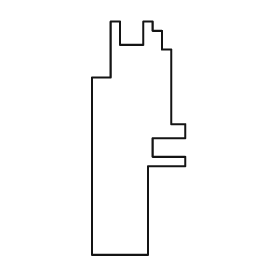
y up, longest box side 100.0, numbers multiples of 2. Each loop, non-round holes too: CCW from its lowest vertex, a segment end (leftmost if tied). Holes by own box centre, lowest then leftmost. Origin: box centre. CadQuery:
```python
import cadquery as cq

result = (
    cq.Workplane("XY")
    .moveTo(-20.0, -50.0)
    .lineTo(4.0, -50.0)
    .lineTo(4.0, -12.0)
    .lineTo(20.0, -12.0)
    .lineTo(20.0, -8.0)
    .lineTo(6.0, -8.0)
    .lineTo(6.0, 0.0)
    .lineTo(20.0, 0.0)
    .lineTo(20.0, 6.0)
    .lineTo(14.0, 6.0)
    .lineTo(14.0, 38.0)
    .lineTo(10.0, 38.0)
    .lineTo(10.0, 46.0)
    .lineTo(6.0, 46.0)
    .lineTo(6.0, 50.0)
    .lineTo(2.0, 50.0)
    .lineTo(2.0, 40.0)
    .lineTo(-8.0, 40.0)
    .lineTo(-8.0, 50.0)
    .lineTo(-12.0, 50.0)
    .lineTo(-12.0, 26.0)
    .lineTo(-20.0, 26.0)
    .close()
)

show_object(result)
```